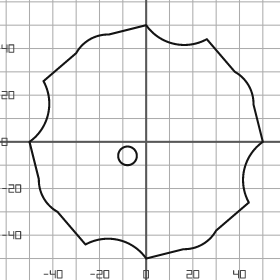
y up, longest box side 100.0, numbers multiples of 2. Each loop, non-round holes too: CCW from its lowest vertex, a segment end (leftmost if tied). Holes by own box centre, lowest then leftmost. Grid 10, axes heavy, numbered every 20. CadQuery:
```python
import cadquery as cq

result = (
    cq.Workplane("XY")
    .moveTo(0.0, -50.0)
    .lineTo(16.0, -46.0)
    .threePointArc((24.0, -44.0), (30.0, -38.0))
    .lineTo(44.0, -26.0)
    .threePointArc((42.0, -12.0), (50.0, 0.0))
    .lineTo(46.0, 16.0)
    .threePointArc((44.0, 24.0), (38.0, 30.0))
    .lineTo(26.0, 44.0)
    .threePointArc((12.0, 42.0), (0.0, 50.0))
    .lineTo(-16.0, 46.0)
    .threePointArc((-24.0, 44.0), (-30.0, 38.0))
    .lineTo(-44.0, 26.0)
    .threePointArc((-42.0, 12.0), (-50.0, 0.0))
    .lineTo(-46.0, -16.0)
    .threePointArc((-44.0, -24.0), (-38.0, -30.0))
    .lineTo(-26.0, -44.0)
    .threePointArc((-12.0, -42.0), (0.0, -50.0))
    .close()
    .moveTo(-8.0, -6.0)
    .circle(4.0)
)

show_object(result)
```